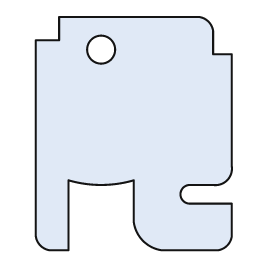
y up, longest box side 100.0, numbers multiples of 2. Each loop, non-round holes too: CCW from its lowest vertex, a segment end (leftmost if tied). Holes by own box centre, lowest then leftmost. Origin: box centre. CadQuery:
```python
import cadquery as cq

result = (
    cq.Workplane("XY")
    .moveTo(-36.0, -50.0)
    .lineTo(-28.0, -50.0)
    .lineTo(-28.0, -20.0)
    .threePointArc((-14.0, -22.0), (0.0, -20.0))
    .lineTo(0.0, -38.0)
    .threePointArc((4.0, -46.0), (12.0, -50.0))
    .lineTo(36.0, -50.0)
    .threePointArc((40.0, -48.0), (42.0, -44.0))
    .lineTo(42.0, -30.0)
    .lineTo(24.0, -30.0)
    .threePointArc((20.0, -26.0), (24.0, -22.0))
    .lineTo(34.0, -22.0)
    .threePointArc((40.0, -20.0), (42.0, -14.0))
    .lineTo(42.0, 34.0)
    .lineTo(34.0, 34.0)
    .lineTo(34.0, 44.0)
    .threePointArc((32.0, 48.0), (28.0, 50.0))
    .lineTo(-32.0, 50.0)
    .lineTo(-32.0, 40.0)
    .lineTo(-42.0, 40.0)
    .lineTo(-42.0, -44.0)
    .threePointArc((-40.0, -48.0), (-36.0, -50.0))
    .close()
    .moveTo(-14.0, 36.0)
    .circle(6.0)
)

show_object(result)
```